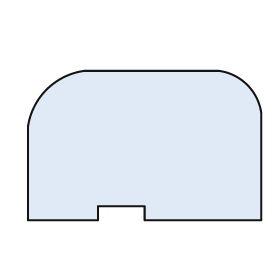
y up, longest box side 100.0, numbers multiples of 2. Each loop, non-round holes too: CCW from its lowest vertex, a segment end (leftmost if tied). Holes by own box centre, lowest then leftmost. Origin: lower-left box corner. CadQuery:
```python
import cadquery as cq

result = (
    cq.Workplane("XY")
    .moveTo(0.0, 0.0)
    .lineTo(30.0, 0.0)
    .lineTo(30.0, 6.0)
    .lineTo(50.0, 6.0)
    .lineTo(50.0, 0.0)
    .lineTo(100.0, 0.0)
    .lineTo(100.0, 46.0)
    .threePointArc((94.0, 58.0), (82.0, 64.0))
    .lineTo(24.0, 64.0)
    .threePointArc((8.0, 56.0), (0.0, 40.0))
    .close()
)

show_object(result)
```